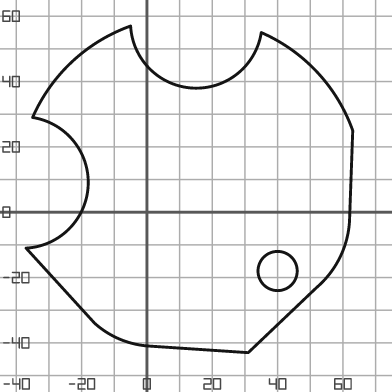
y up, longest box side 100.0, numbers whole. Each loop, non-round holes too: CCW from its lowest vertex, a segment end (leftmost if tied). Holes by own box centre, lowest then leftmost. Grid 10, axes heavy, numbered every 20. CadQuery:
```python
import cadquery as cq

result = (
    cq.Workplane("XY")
    .moveTo(31.0, -43.0)
    .lineTo(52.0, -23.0)
    .threePointArc((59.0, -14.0), (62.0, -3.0))
    .lineTo(63.0, 25.0)
    .threePointArc((52.0, 43.0), (35.0, 55.0))
    .threePointArc((14.0, 38.0), (-5.0, 57.0))
    .threePointArc((-23.0, 46.0), (-35.0, 29.0))
    .threePointArc((-18.0, 8.0), (-37.0, -11.0))
    .lineTo(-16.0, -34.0)
    .threePointArc((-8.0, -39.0), (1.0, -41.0))
    .close()
    .moveTo(40.0, -18.0)
    .circle(6.0)
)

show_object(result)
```